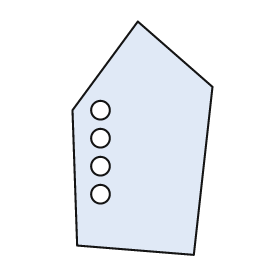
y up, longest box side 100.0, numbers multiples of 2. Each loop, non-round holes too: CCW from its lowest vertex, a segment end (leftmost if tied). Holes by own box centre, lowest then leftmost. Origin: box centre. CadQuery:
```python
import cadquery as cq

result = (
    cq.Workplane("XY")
    .moveTo(22.0, -50.0)
    .lineTo(30.0, 22.0)
    .lineTo(-2.0, 50.0)
    .lineTo(-30.0, 12.0)
    .lineTo(-28.0, -46.0)
    .close()
    .moveTo(-18.0, -24.0)
    .circle(4.0)
    .moveTo(-18.0, -12.0)
    .circle(4.0)
    .moveTo(-18.0, 0.0)
    .circle(4.0)
    .moveTo(-18.0, 12.0)
    .circle(4.0)
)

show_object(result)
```